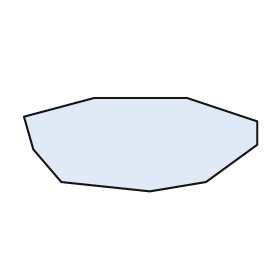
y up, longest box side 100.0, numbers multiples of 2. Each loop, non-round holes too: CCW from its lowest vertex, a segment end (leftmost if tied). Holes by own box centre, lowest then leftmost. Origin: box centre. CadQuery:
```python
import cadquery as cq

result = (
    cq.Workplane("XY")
    .moveTo(4.0, -20.0)
    .lineTo(28.0, -16.0)
    .lineTo(50.0, 0.0)
    .lineTo(50.0, 10.0)
    .lineTo(20.0, 20.0)
    .lineTo(-20.0, 20.0)
    .lineTo(-50.0, 12.0)
    .lineTo(-46.0, -2.0)
    .lineTo(-34.0, -16.0)
    .close()
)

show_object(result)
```